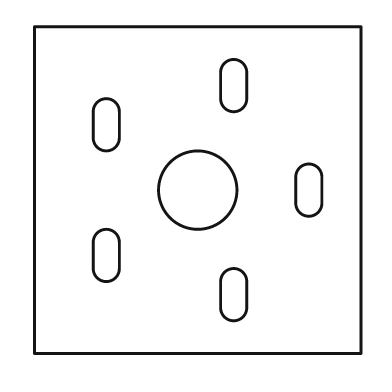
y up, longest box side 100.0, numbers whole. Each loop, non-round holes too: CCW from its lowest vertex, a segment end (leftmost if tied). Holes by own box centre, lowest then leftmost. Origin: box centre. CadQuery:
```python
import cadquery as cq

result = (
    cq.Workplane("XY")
    .moveTo(-50.0, -50.0)
    .lineTo(50.0, -50.0)
    .lineTo(50.0, 50.0)
    .lineTo(-50.0, 50.0)
    .close()
    .moveTo(7.0, -36.0)
    .threePointArc((11.0, -40.0), (15.0, -36.0))
    .lineTo(15.0, -28.0)
    .threePointArc((11.0, -24.0), (7.0, -28.0))
    .close()
    .moveTo(-32.0, -24.0)
    .threePointArc((-28.0, -28.0), (-24.0, -24.0))
    .lineTo(-24.0, -16.0)
    .threePointArc((-28.0, -12.0), (-32.0, -16.0))
    .close()
    .moveTo(0.0, 0.0)
    .circle(12.0)
    .moveTo(30.0, -4.0)
    .threePointArc((34.0, -8.0), (38.0, -4.0))
    .lineTo(38.0, 4.0)
    .threePointArc((34.0, 8.0), (30.0, 4.0))
    .close()
    .moveTo(-32.0, 16.0)
    .threePointArc((-28.0, 12.0), (-24.0, 16.0))
    .lineTo(-24.0, 24.0)
    .threePointArc((-28.0, 28.0), (-32.0, 24.0))
    .close()
    .moveTo(7.0, 28.0)
    .threePointArc((11.0, 24.0), (15.0, 28.0))
    .lineTo(15.0, 36.0)
    .threePointArc((11.0, 40.0), (7.0, 36.0))
    .close()
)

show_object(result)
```